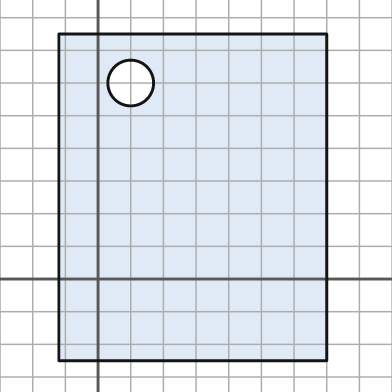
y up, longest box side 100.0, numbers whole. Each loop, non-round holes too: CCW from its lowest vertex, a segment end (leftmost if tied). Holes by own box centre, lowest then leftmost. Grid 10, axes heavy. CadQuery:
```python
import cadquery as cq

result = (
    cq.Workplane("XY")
    .moveTo(-12.0, -25.0)
    .lineTo(70.0, -25.0)
    .lineTo(70.0, 75.0)
    .lineTo(-12.0, 75.0)
    .close()
    .moveTo(10.0, 60.0)
    .circle(7.0)
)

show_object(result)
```